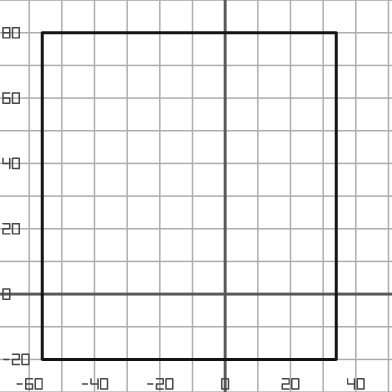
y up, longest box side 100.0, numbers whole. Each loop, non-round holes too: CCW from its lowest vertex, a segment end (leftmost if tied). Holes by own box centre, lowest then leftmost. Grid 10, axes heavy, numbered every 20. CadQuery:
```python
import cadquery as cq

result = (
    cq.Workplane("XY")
    .moveTo(-56.0, -20.0)
    .lineTo(34.0, -20.0)
    .lineTo(34.0, 80.0)
    .lineTo(-56.0, 80.0)
    .close()
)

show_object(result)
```